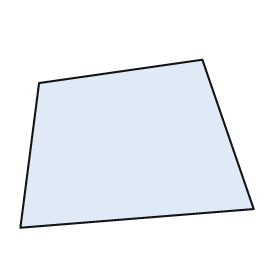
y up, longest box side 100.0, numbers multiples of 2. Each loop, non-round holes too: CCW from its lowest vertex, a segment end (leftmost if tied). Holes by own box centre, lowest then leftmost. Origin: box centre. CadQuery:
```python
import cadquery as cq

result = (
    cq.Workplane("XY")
    .moveTo(-50.0, -36.0)
    .lineTo(50.0, -28.0)
    .lineTo(28.0, 36.0)
    .lineTo(-42.0, 26.0)
    .close()
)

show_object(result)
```